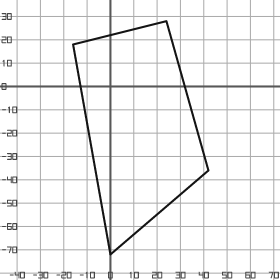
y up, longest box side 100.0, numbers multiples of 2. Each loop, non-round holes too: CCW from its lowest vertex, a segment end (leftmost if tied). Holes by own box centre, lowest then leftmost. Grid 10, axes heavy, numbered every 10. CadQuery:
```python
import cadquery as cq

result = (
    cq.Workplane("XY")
    .moveTo(0.0, -72.0)
    .lineTo(42.0, -36.0)
    .lineTo(24.0, 28.0)
    .lineTo(-16.0, 18.0)
    .close()
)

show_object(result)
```